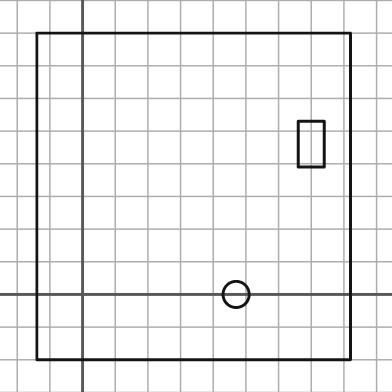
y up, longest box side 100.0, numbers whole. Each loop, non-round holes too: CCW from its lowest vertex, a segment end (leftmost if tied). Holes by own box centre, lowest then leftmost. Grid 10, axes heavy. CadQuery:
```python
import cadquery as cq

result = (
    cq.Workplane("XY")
    .moveTo(-14.0, -20.0)
    .lineTo(82.0, -20.0)
    .lineTo(82.0, 80.0)
    .lineTo(-14.0, 80.0)
    .close()
    .moveTo(47.0, 0.0)
    .circle(4.0)
    .moveTo(66.0, 39.0)
    .lineTo(74.0, 39.0)
    .lineTo(74.0, 53.0)
    .lineTo(66.0, 53.0)
    .close()
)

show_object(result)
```